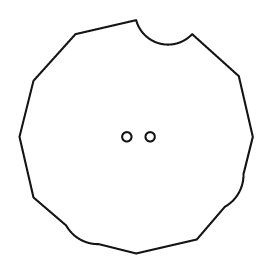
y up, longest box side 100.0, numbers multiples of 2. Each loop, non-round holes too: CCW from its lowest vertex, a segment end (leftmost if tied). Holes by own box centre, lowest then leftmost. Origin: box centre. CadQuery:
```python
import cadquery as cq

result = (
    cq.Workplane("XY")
    .moveTo(0.0, -50.0)
    .lineTo(26.0, -44.0)
    .lineTo(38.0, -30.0)
    .threePointArc((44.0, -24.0), (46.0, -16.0))
    .lineTo(50.0, 0.0)
    .lineTo(44.0, 26.0)
    .lineTo(24.0, 44.0)
    .threePointArc((10.0, 40.0), (0.0, 50.0))
    .lineTo(-26.0, 44.0)
    .lineTo(-44.0, 24.0)
    .lineTo(-50.0, 0.0)
    .lineTo(-44.0, -26.0)
    .lineTo(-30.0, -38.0)
    .threePointArc((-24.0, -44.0), (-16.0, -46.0))
    .close()
    .moveTo(-4.0, 0.0)
    .circle(2.0)
    .moveTo(6.0, 0.0)
    .circle(2.0)
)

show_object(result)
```